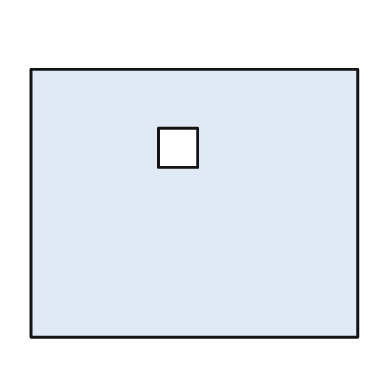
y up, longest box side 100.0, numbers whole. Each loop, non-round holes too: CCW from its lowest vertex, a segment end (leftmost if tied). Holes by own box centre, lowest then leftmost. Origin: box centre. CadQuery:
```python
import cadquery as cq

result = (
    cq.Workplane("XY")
    .moveTo(-50.0, -41.0)
    .lineTo(50.0, -41.0)
    .lineTo(50.0, 41.0)
    .lineTo(-50.0, 41.0)
    .close()
    .moveTo(-11.0, 11.0)
    .lineTo(1.0, 11.0)
    .lineTo(1.0, 23.0)
    .lineTo(-11.0, 23.0)
    .close()
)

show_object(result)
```